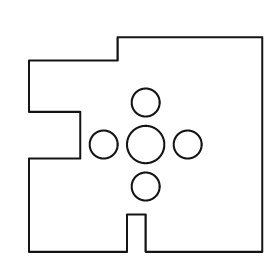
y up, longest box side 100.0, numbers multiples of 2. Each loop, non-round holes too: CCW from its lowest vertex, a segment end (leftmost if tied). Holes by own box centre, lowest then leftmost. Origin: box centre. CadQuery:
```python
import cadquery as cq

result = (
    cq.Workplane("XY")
    .moveTo(-50.0, -46.0)
    .lineTo(-8.0, -46.0)
    .lineTo(-8.0, -30.0)
    .lineTo(0.0, -30.0)
    .lineTo(0.0, -46.0)
    .lineTo(50.0, -46.0)
    .lineTo(50.0, 46.0)
    .lineTo(-12.0, 46.0)
    .lineTo(-12.0, 36.0)
    .lineTo(-50.0, 36.0)
    .lineTo(-50.0, 14.0)
    .lineTo(-28.0, 14.0)
    .lineTo(-28.0, -6.0)
    .lineTo(-50.0, -6.0)
    .close()
    .moveTo(0.0, -18.0)
    .circle(6.0)
    .moveTo(-18.0, 0.0)
    .circle(6.0)
    .moveTo(0.0, 0.0)
    .circle(8.0)
    .moveTo(18.0, 0.0)
    .circle(6.0)
    .moveTo(0.0, 18.0)
    .circle(6.0)
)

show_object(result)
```